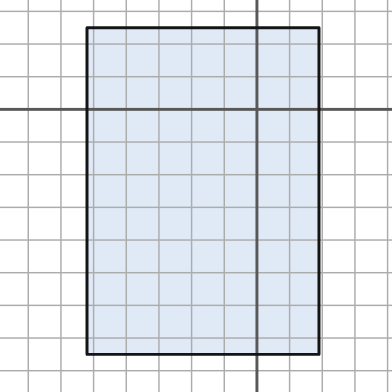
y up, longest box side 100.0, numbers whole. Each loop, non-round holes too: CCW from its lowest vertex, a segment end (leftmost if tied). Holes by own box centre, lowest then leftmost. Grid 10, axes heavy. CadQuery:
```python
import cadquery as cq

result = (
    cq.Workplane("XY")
    .moveTo(-52.0, -75.0)
    .lineTo(19.0, -75.0)
    .lineTo(19.0, 25.0)
    .lineTo(-52.0, 25.0)
    .close()
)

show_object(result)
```